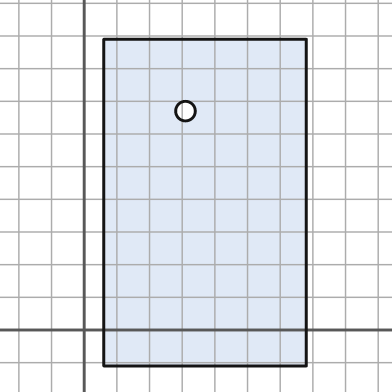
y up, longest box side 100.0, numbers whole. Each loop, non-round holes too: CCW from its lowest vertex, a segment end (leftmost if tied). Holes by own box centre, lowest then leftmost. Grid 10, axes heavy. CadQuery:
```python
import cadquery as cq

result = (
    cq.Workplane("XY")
    .moveTo(6.0, -11.0)
    .lineTo(68.0, -11.0)
    .lineTo(68.0, 89.0)
    .lineTo(6.0, 89.0)
    .close()
    .moveTo(31.0, 67.0)
    .circle(3.0)
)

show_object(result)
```